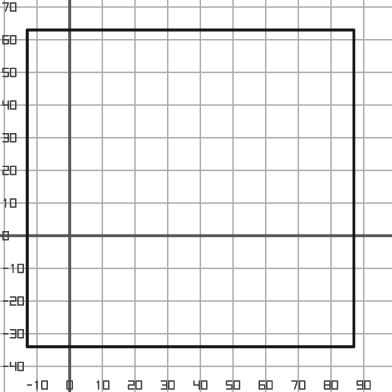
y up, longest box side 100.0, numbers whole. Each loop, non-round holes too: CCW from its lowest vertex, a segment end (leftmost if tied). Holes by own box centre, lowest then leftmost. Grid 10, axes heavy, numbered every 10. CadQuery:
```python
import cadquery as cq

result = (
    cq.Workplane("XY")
    .moveTo(-13.0, -34.0)
    .lineTo(87.0, -34.0)
    .lineTo(87.0, 63.0)
    .lineTo(-13.0, 63.0)
    .close()
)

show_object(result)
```